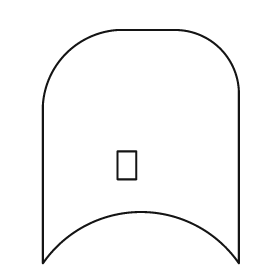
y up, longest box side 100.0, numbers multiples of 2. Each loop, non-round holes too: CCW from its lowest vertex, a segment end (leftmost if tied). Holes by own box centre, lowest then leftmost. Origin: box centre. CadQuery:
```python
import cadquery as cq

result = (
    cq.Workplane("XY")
    .moveTo(-42.0, -50.0)
    .threePointArc((0.0, -28.0), (42.0, -50.0))
    .lineTo(42.0, 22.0)
    .threePointArc((34.0, 42.0), (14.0, 50.0))
    .lineTo(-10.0, 50.0)
    .threePointArc((-32.0, 40.0), (-42.0, 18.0))
    .close()
    .moveTo(-10.0, -14.0)
    .lineTo(-2.0, -14.0)
    .lineTo(-2.0, -2.0)
    .lineTo(-10.0, -2.0)
    .close()
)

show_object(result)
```